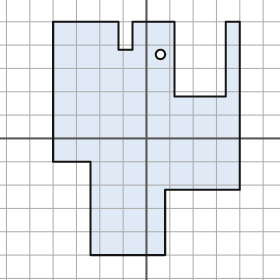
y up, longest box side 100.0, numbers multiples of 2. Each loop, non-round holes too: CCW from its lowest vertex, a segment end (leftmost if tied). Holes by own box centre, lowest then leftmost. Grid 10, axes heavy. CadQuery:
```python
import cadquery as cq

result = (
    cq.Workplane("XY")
    .moveTo(-24.0, -50.0)
    .lineTo(8.0, -50.0)
    .lineTo(8.0, -22.0)
    .lineTo(40.0, -22.0)
    .lineTo(40.0, 50.0)
    .lineTo(34.0, 50.0)
    .lineTo(34.0, 18.0)
    .lineTo(12.0, 18.0)
    .lineTo(12.0, 50.0)
    .lineTo(-6.0, 50.0)
    .lineTo(-6.0, 38.0)
    .lineTo(-12.0, 38.0)
    .lineTo(-12.0, 50.0)
    .lineTo(-40.0, 50.0)
    .lineTo(-40.0, -10.0)
    .lineTo(-24.0, -10.0)
    .close()
    .moveTo(6.0, 36.0)
    .circle(2.0)
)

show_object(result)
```